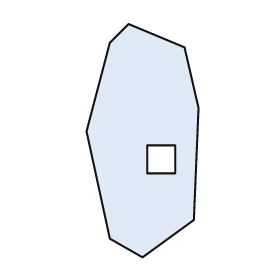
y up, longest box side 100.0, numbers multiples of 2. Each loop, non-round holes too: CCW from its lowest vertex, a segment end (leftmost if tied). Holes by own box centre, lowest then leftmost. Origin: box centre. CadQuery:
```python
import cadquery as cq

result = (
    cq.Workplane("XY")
    .moveTo(0.0, -50.0)
    .lineTo(22.0, -34.0)
    .lineTo(24.0, 14.0)
    .lineTo(18.0, 40.0)
    .lineTo(-6.0, 50.0)
    .lineTo(-14.0, 42.0)
    .lineTo(-24.0, 4.0)
    .lineTo(-14.0, -42.0)
    .close()
    .moveTo(2.0, -14.0)
    .lineTo(14.0, -14.0)
    .lineTo(14.0, -2.0)
    .lineTo(2.0, -2.0)
    .close()
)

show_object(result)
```